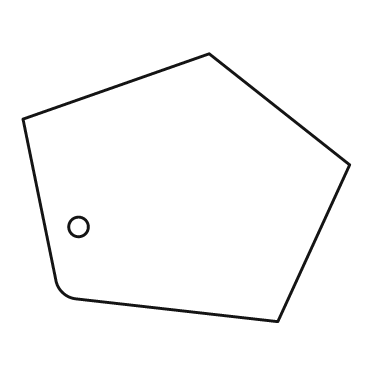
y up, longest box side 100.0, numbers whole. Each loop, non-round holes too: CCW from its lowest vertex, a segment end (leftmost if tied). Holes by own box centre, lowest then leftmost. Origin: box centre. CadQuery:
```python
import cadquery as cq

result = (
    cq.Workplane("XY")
    .moveTo(28.0, -41.0)
    .lineTo(50.0, 7.0)
    .lineTo(7.0, 41.0)
    .lineTo(-50.0, 21.0)
    .lineTo(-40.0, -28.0)
    .threePointArc((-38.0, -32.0), (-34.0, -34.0))
    .close()
    .moveTo(-33.0, -12.0)
    .circle(3.0)
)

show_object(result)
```